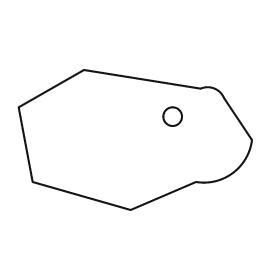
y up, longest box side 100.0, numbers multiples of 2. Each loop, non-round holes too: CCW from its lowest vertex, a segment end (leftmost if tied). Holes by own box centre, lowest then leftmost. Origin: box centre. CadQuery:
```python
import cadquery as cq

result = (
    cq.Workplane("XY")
    .moveTo(-2.0, -30.0)
    .lineTo(26.0, -18.0)
    .threePointArc((42.0, -14.0), (50.0, 0.0))
    .lineTo(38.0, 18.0)
    .threePointArc((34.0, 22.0), (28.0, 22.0))
    .lineTo(-22.0, 30.0)
    .lineTo(-50.0, 14.0)
    .lineTo(-44.0, -18.0)
    .close()
    .moveTo(16.0, 10.0)
    .circle(4.0)
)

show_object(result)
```